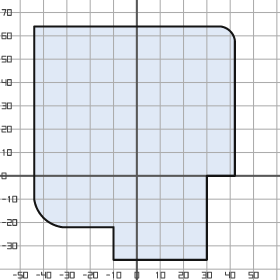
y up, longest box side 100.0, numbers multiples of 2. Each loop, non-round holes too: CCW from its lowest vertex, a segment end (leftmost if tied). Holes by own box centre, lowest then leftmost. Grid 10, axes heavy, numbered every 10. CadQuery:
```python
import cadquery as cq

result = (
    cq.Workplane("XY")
    .moveTo(-10.0, -36.0)
    .lineTo(30.0, -36.0)
    .lineTo(30.0, 0.0)
    .lineTo(42.0, 0.0)
    .lineTo(42.0, 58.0)
    .threePointArc((40.0, 62.0), (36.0, 64.0))
    .lineTo(-44.0, 64.0)
    .lineTo(-44.0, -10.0)
    .threePointArc((-40.0, -18.0), (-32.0, -22.0))
    .lineTo(-10.0, -22.0)
    .close()
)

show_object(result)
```